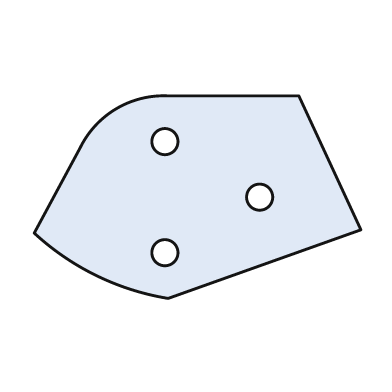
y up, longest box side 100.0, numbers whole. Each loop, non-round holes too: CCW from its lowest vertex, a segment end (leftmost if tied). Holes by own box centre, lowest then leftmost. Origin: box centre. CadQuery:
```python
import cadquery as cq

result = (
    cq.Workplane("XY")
    .moveTo(-9.0, -31.0)
    .lineTo(50.0, -10.0)
    .lineTo(31.0, 31.0)
    .lineTo(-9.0, 31.0)
    .threePointArc((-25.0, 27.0), (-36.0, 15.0))
    .lineTo(-50.0, -11.0)
    .threePointArc((-31.0, -24.0), (-9.0, -31.0))
    .close()
    .moveTo(-10.0, -17.0)
    .circle(4.0)
    .moveTo(19.0, 0.0)
    .circle(4.0)
    .moveTo(-10.0, 17.0)
    .circle(4.0)
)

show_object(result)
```